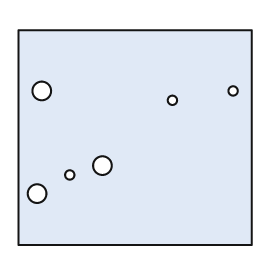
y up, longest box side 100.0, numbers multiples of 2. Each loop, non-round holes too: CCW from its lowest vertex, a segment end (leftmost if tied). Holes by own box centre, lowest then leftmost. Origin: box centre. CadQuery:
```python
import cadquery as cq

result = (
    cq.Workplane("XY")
    .moveTo(-50.0, -46.0)
    .lineTo(50.0, -46.0)
    .lineTo(50.0, 46.0)
    .lineTo(-50.0, 46.0)
    .close()
    .moveTo(-42.0, -24.0)
    .circle(4.0)
    .moveTo(-28.0, -16.0)
    .circle(2.0)
    .moveTo(-14.0, -12.0)
    .circle(4.0)
    .moveTo(16.0, 16.0)
    .circle(2.0)
    .moveTo(-40.0, 20.0)
    .circle(4.0)
    .moveTo(42.0, 20.0)
    .circle(2.0)
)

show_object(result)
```